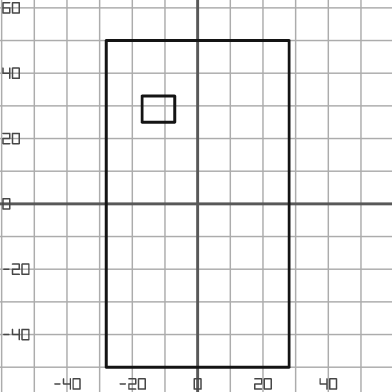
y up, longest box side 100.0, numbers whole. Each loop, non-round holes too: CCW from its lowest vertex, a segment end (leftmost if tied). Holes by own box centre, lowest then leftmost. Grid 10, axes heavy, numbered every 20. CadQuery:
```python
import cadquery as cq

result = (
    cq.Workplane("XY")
    .moveTo(-28.0, -50.0)
    .lineTo(28.0, -50.0)
    .lineTo(28.0, 50.0)
    .lineTo(-28.0, 50.0)
    .close()
    .moveTo(-17.0, 25.0)
    .lineTo(-7.0, 25.0)
    .lineTo(-7.0, 33.0)
    .lineTo(-17.0, 33.0)
    .close()
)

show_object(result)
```